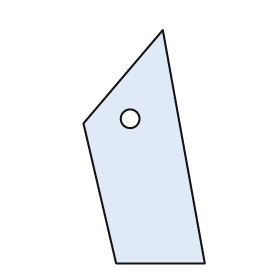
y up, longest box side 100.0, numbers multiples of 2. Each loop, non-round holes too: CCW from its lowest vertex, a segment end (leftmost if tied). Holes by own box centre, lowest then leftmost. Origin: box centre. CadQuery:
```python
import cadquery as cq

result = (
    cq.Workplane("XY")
    .moveTo(-12.0, -50.0)
    .lineTo(26.0, -50.0)
    .lineTo(8.0, 50.0)
    .lineTo(-26.0, 10.0)
    .close()
    .moveTo(-6.0, 12.0)
    .circle(4.0)
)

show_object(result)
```